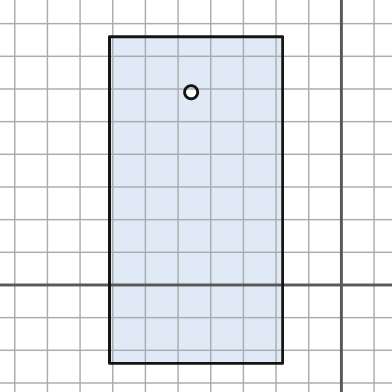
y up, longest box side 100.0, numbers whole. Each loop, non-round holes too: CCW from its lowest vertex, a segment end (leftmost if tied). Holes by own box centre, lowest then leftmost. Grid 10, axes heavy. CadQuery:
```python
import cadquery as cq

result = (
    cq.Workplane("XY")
    .moveTo(-71.0, -24.0)
    .lineTo(-18.0, -24.0)
    .lineTo(-18.0, 76.0)
    .lineTo(-71.0, 76.0)
    .close()
    .moveTo(-46.0, 59.0)
    .circle(2.0)
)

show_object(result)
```